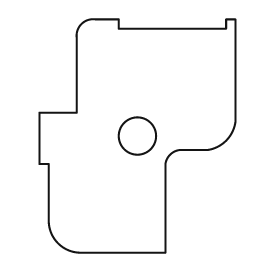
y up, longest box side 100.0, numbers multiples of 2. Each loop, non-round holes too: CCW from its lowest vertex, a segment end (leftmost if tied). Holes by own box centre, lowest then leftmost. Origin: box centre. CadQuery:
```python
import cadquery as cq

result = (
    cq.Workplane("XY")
    .moveTo(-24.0, -50.0)
    .lineTo(12.0, -50.0)
    .lineTo(12.0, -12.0)
    .threePointArc((14.0, -8.0), (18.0, -6.0))
    .lineTo(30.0, -6.0)
    .threePointArc((38.0, -2.0), (42.0, 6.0))
    .lineTo(42.0, 50.0)
    .lineTo(38.0, 50.0)
    .lineTo(38.0, 46.0)
    .lineTo(-8.0, 46.0)
    .lineTo(-8.0, 50.0)
    .lineTo(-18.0, 50.0)
    .threePointArc((-24.0, 48.0), (-26.0, 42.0))
    .lineTo(-26.0, 10.0)
    .lineTo(-42.0, 10.0)
    .lineTo(-42.0, -12.0)
    .lineTo(-38.0, -12.0)
    .lineTo(-38.0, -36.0)
    .threePointArc((-34.0, -46.0), (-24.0, -50.0))
    .close()
    .moveTo(0.0, 0.0)
    .circle(8.0)
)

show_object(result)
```